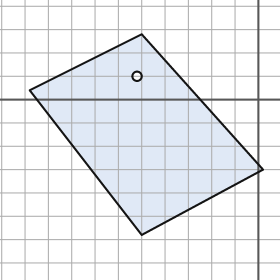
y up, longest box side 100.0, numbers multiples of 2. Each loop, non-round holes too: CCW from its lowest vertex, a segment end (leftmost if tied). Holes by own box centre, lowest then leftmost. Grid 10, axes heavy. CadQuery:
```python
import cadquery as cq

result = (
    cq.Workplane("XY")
    .moveTo(-50.0, -58.0)
    .lineTo(2.0, -30.0)
    .lineTo(-50.0, 28.0)
    .lineTo(-98.0, 4.0)
    .close()
    .moveTo(-52.0, 10.0)
    .circle(2.0)
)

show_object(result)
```